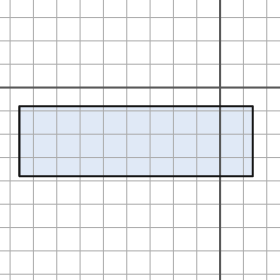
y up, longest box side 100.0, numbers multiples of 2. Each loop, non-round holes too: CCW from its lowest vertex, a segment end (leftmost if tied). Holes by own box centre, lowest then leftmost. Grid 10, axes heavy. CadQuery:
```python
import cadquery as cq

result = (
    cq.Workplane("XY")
    .moveTo(-86.0, -38.0)
    .lineTo(14.0, -38.0)
    .lineTo(14.0, -8.0)
    .lineTo(-86.0, -8.0)
    .close()
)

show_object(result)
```